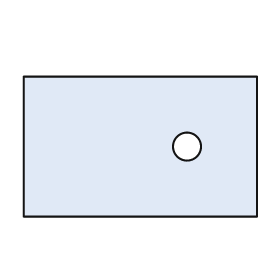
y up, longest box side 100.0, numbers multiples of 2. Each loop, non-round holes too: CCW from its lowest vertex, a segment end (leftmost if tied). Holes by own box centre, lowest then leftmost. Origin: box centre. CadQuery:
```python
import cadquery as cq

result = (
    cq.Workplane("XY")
    .moveTo(-50.0, -30.0)
    .lineTo(50.0, -30.0)
    .lineTo(50.0, 30.0)
    .lineTo(-50.0, 30.0)
    .close()
    .moveTo(20.0, 0.0)
    .circle(6.0)
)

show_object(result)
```